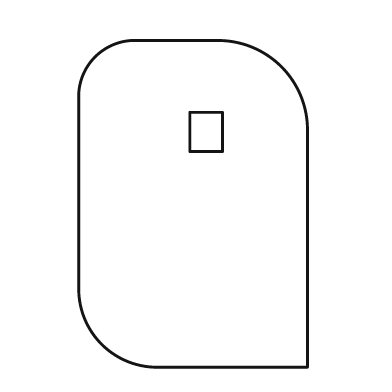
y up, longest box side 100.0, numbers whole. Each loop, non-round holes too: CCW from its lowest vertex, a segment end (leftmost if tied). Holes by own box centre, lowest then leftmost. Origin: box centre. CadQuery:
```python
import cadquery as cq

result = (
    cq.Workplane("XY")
    .moveTo(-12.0, -50.0)
    .lineTo(35.0, -50.0)
    .lineTo(35.0, 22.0)
    .threePointArc((27.0, 42.0), (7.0, 50.0))
    .lineTo(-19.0, 50.0)
    .threePointArc((-30.0, 45.0), (-35.0, 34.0))
    .lineTo(-35.0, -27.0)
    .threePointArc((-28.0, -43.0), (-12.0, -50.0))
    .close()
    .moveTo(-1.0, 16.0)
    .lineTo(9.0, 16.0)
    .lineTo(9.0, 28.0)
    .lineTo(-1.0, 28.0)
    .close()
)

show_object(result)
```